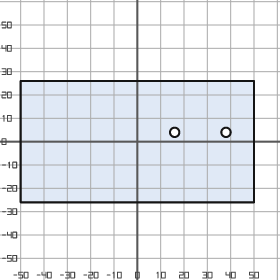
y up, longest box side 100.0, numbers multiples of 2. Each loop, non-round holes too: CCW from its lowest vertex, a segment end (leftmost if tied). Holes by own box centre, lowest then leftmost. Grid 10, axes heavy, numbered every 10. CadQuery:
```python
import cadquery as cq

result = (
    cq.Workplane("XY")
    .moveTo(-50.0, -26.0)
    .lineTo(50.0, -26.0)
    .lineTo(50.0, 26.0)
    .lineTo(-50.0, 26.0)
    .close()
    .moveTo(16.0, 4.0)
    .circle(2.0)
    .moveTo(38.0, 4.0)
    .circle(2.0)
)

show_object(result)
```